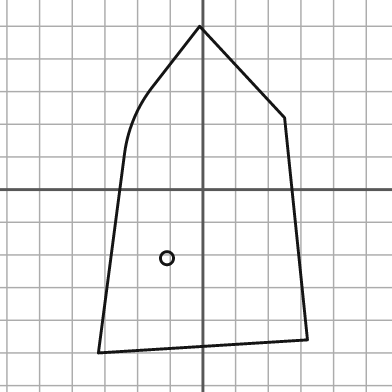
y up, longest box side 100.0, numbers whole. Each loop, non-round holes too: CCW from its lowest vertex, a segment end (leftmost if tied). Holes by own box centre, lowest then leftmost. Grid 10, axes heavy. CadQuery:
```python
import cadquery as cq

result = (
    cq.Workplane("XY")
    .moveTo(-32.0, -50.0)
    .lineTo(32.0, -46.0)
    .lineTo(25.0, 22.0)
    .lineTo(-1.0, 50.0)
    .lineTo(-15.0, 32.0)
    .threePointArc((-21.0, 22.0), (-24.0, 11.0))
    .close()
    .moveTo(-11.0, -21.0)
    .circle(2.0)
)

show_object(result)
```